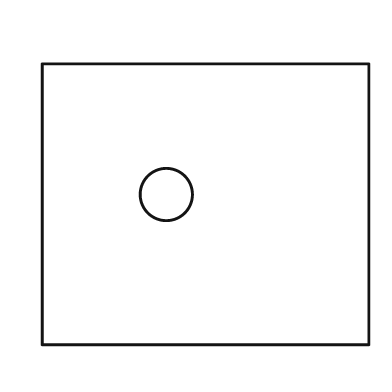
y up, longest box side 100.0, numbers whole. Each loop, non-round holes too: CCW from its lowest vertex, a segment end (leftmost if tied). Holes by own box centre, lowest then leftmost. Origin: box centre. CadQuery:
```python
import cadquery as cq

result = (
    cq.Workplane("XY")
    .moveTo(-50.0, -43.0)
    .lineTo(50.0, -43.0)
    .lineTo(50.0, 43.0)
    .lineTo(-50.0, 43.0)
    .close()
    .moveTo(-12.0, 3.0)
    .circle(8.0)
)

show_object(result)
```